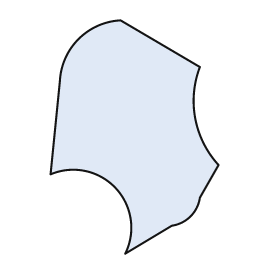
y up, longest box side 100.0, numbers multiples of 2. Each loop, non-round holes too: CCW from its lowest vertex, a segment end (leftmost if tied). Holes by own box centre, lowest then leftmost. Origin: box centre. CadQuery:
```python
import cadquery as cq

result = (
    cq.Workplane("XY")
    .moveTo(-4.0, -50.0)
    .lineTo(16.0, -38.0)
    .threePointArc((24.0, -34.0), (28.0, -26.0))
    .lineTo(36.0, -12.0)
    .threePointArc((26.0, 8.0), (28.0, 30.0))
    .lineTo(-6.0, 50.0)
    .threePointArc((-24.0, 42.0), (-32.0, 24.0))
    .lineTo(-36.0, -16.0)
    .threePointArc((-8.0, -22.0), (-4.0, -50.0))
    .close()
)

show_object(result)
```